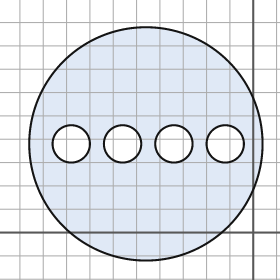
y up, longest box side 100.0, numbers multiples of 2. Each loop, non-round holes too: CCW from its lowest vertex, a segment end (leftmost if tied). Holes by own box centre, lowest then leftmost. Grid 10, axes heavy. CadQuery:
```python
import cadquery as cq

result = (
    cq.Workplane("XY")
    .moveTo(-46.0, 38.0)
    .circle(50.0)
    .moveTo(-78.0, 38.0)
    .circle(8.0)
    .moveTo(-56.0, 38.0)
    .circle(8.0)
    .moveTo(-34.0, 38.0)
    .circle(8.0)
    .moveTo(-12.0, 38.0)
    .circle(8.0)
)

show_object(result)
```